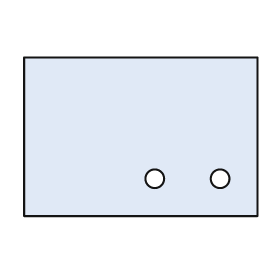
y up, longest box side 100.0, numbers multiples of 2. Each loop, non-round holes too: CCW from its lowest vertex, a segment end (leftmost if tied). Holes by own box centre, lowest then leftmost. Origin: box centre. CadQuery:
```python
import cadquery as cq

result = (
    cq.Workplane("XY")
    .moveTo(-50.0, -34.0)
    .lineTo(50.0, -34.0)
    .lineTo(50.0, 34.0)
    .lineTo(-50.0, 34.0)
    .close()
    .moveTo(6.0, -18.0)
    .circle(4.0)
    .moveTo(34.0, -18.0)
    .circle(4.0)
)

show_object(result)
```